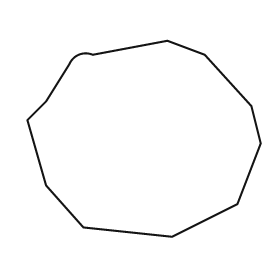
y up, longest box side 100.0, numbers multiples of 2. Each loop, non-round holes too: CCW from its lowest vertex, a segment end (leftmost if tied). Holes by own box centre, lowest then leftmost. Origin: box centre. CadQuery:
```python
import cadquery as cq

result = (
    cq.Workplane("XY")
    .moveTo(12.0, -42.0)
    .lineTo(40.0, -28.0)
    .lineTo(50.0, -2.0)
    .lineTo(46.0, 14.0)
    .lineTo(26.0, 36.0)
    .lineTo(10.0, 42.0)
    .lineTo(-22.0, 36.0)
    .threePointArc((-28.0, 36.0), (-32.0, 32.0))
    .lineTo(-42.0, 16.0)
    .lineTo(-50.0, 8.0)
    .lineTo(-42.0, -20.0)
    .lineTo(-26.0, -38.0)
    .close()
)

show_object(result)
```